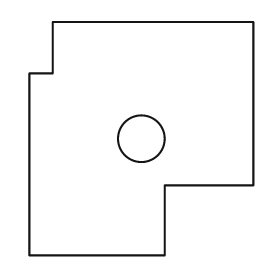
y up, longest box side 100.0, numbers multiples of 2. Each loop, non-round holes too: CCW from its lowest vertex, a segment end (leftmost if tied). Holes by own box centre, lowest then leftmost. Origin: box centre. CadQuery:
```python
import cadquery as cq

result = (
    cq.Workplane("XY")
    .moveTo(-48.0, -50.0)
    .lineTo(10.0, -50.0)
    .lineTo(10.0, -20.0)
    .lineTo(48.0, -20.0)
    .lineTo(48.0, 50.0)
    .lineTo(-38.0, 50.0)
    .lineTo(-38.0, 28.0)
    .lineTo(-48.0, 28.0)
    .close()
    .moveTo(0.0, 0.0)
    .circle(10.0)
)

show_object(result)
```